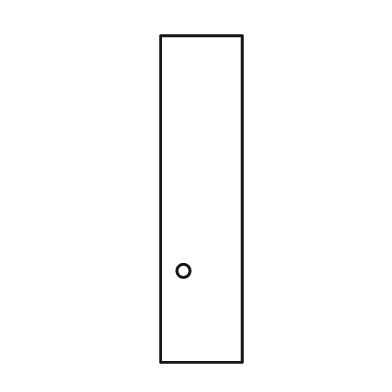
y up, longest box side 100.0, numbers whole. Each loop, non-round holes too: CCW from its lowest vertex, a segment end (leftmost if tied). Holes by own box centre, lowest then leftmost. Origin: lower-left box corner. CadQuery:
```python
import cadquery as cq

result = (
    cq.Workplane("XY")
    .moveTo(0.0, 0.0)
    .lineTo(25.0, 0.0)
    .lineTo(25.0, 100.0)
    .lineTo(0.0, 100.0)
    .close()
    .moveTo(7.0, 28.0)
    .circle(2.0)
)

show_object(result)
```